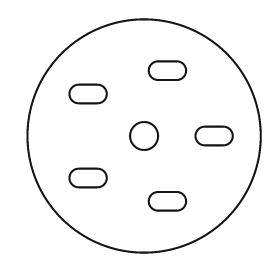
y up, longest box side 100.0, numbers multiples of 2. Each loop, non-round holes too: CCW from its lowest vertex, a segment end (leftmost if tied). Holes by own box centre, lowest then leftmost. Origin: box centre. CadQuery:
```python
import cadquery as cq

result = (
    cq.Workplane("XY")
    .moveTo(0.0, 0.0)
    .circle(50.0)
    .moveTo(6.0, -32.0)
    .lineTo(14.0, -32.0)
    .threePointArc((18.0, -28.0), (14.0, -24.0))
    .lineTo(6.0, -24.0)
    .threePointArc((2.0, -28.0), (6.0, -32.0))
    .close()
    .moveTo(-28.0, -22.0)
    .lineTo(-20.0, -22.0)
    .threePointArc((-16.0, -18.0), (-20.0, -14.0))
    .lineTo(-28.0, -14.0)
    .threePointArc((-32.0, -18.0), (-28.0, -22.0))
    .close()
    .moveTo(0.0, 0.0)
    .circle(6.0)
    .moveTo(26.0, -4.0)
    .lineTo(34.0, -4.0)
    .threePointArc((38.0, 0.0), (34.0, 4.0))
    .lineTo(26.0, 4.0)
    .threePointArc((22.0, 0.0), (26.0, -4.0))
    .close()
    .moveTo(-28.0, 14.0)
    .lineTo(-20.0, 14.0)
    .threePointArc((-16.0, 18.0), (-20.0, 22.0))
    .lineTo(-28.0, 22.0)
    .threePointArc((-32.0, 18.0), (-28.0, 14.0))
    .close()
    .moveTo(6.0, 24.0)
    .lineTo(14.0, 24.0)
    .threePointArc((18.0, 28.0), (14.0, 32.0))
    .lineTo(6.0, 32.0)
    .threePointArc((2.0, 28.0), (6.0, 24.0))
    .close()
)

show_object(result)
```